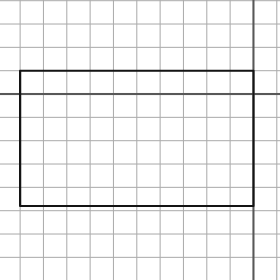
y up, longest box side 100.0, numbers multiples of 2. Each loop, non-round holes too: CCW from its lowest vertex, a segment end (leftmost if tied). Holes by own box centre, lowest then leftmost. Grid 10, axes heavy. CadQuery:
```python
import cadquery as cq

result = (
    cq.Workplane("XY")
    .moveTo(-100.0, -48.0)
    .lineTo(0.0, -48.0)
    .lineTo(0.0, 10.0)
    .lineTo(-100.0, 10.0)
    .close()
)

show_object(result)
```